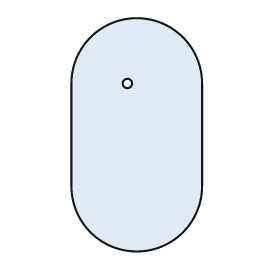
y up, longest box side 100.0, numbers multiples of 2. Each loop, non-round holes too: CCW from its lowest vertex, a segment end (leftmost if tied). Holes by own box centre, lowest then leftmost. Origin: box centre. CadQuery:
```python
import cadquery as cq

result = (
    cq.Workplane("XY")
    .moveTo(-28.0, -22.0)
    .threePointArc((0.0, -50.0), (28.0, -22.0))
    .lineTo(28.0, 22.0)
    .threePointArc((0.0, 50.0), (-28.0, 22.0))
    .close()
    .moveTo(-4.0, 22.0)
    .circle(2.0)
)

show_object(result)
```